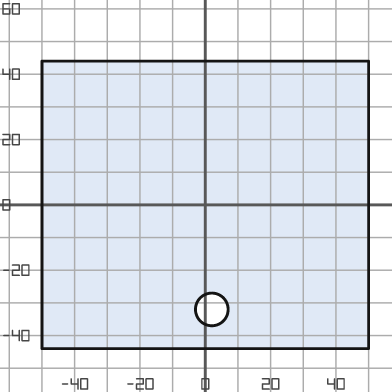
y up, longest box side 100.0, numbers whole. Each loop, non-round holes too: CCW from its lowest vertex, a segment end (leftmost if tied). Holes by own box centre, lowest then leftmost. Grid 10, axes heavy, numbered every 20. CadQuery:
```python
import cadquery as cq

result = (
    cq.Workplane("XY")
    .moveTo(-50.0, -44.0)
    .lineTo(50.0, -44.0)
    .lineTo(50.0, 44.0)
    .lineTo(-50.0, 44.0)
    .close()
    .moveTo(2.0, -32.0)
    .circle(5.0)
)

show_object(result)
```